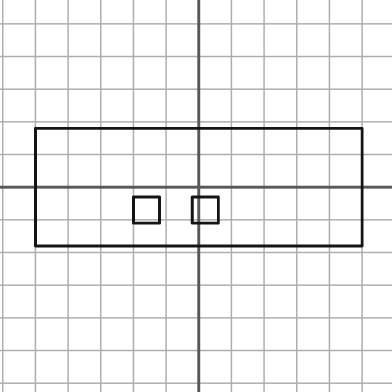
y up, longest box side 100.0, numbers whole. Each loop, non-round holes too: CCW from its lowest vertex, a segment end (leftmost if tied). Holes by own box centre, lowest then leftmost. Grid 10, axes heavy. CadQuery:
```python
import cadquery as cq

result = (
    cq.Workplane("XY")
    .moveTo(-50.0, -18.0)
    .lineTo(50.0, -18.0)
    .lineTo(50.0, 18.0)
    .lineTo(-50.0, 18.0)
    .close()
    .moveTo(-20.0, -11.0)
    .lineTo(-12.0, -11.0)
    .lineTo(-12.0, -3.0)
    .lineTo(-20.0, -3.0)
    .close()
    .moveTo(-2.0, -11.0)
    .lineTo(6.0, -11.0)
    .lineTo(6.0, -3.0)
    .lineTo(-2.0, -3.0)
    .close()
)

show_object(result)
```